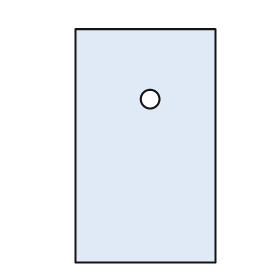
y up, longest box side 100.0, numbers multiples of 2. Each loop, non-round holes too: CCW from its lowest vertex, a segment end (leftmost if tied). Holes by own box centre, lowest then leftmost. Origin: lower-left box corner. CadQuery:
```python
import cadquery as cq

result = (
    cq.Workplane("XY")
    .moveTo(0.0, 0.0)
    .lineTo(60.0, 0.0)
    .lineTo(60.0, 100.0)
    .lineTo(0.0, 100.0)
    .close()
    .moveTo(32.0, 70.0)
    .circle(4.0)
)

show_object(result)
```